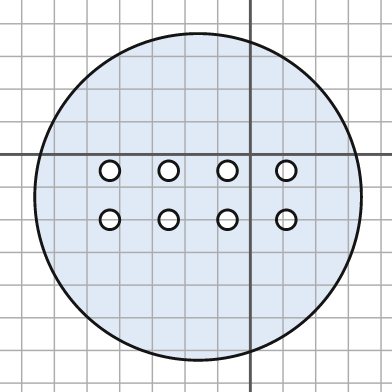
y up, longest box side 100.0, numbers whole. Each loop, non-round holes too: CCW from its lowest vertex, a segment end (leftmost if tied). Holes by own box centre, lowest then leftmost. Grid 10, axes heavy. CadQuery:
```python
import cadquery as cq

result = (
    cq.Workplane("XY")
    .moveTo(-16.0, -13.0)
    .circle(50.0)
    .moveTo(-43.0, -20.0)
    .circle(3.0)
    .moveTo(-25.0, -20.0)
    .circle(3.0)
    .moveTo(-7.0, -20.0)
    .circle(3.0)
    .moveTo(11.0, -20.0)
    .circle(3.0)
    .moveTo(-43.0, -5.0)
    .circle(3.0)
    .moveTo(-25.0, -5.0)
    .circle(3.0)
    .moveTo(-7.0, -5.0)
    .circle(3.0)
    .moveTo(11.0, -5.0)
    .circle(3.0)
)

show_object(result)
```